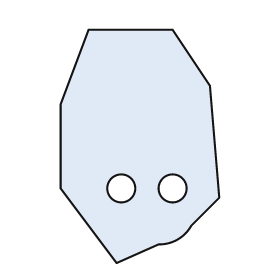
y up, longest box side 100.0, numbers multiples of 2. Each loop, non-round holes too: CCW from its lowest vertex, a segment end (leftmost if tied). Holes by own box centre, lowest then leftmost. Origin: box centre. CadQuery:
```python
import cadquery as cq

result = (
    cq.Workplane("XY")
    .moveTo(-10.0, -50.0)
    .lineTo(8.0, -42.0)
    .threePointArc((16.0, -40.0), (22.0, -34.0))
    .lineTo(34.0, -22.0)
    .lineTo(30.0, 26.0)
    .lineTo(14.0, 50.0)
    .lineTo(-22.0, 50.0)
    .lineTo(-34.0, 18.0)
    .lineTo(-34.0, -18.0)
    .close()
    .moveTo(-8.0, -18.0)
    .circle(6.0)
    .moveTo(14.0, -18.0)
    .circle(6.0)
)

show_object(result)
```